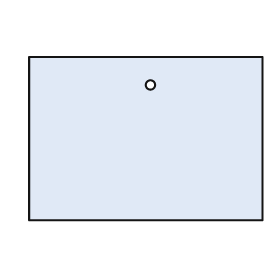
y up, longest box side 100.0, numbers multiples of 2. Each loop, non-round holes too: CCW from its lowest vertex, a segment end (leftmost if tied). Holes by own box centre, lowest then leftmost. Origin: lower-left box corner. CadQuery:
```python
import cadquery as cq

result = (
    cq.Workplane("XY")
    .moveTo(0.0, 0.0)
    .lineTo(100.0, 0.0)
    .lineTo(100.0, 70.0)
    .lineTo(0.0, 70.0)
    .close()
    .moveTo(52.0, 58.0)
    .circle(2.0)
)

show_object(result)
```